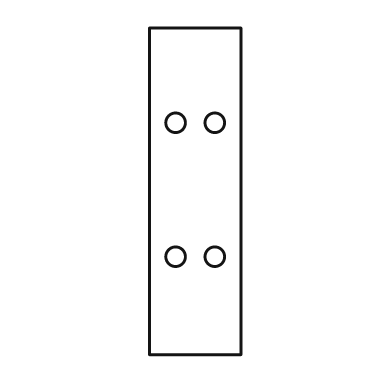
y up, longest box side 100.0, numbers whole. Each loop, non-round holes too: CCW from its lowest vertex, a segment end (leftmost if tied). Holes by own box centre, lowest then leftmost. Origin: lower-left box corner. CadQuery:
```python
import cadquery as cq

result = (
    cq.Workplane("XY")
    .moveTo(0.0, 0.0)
    .lineTo(28.0, 0.0)
    .lineTo(28.0, 100.0)
    .lineTo(0.0, 100.0)
    .close()
    .moveTo(8.0, 30.0)
    .circle(3.0)
    .moveTo(20.0, 30.0)
    .circle(3.0)
    .moveTo(8.0, 71.0)
    .circle(3.0)
    .moveTo(20.0, 71.0)
    .circle(3.0)
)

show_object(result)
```